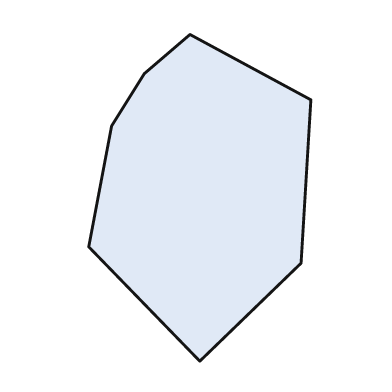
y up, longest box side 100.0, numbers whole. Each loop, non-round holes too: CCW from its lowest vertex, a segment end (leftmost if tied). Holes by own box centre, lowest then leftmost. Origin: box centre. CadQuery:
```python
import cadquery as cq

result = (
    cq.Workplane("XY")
    .moveTo(0.0, -50.0)
    .lineTo(31.0, -20.0)
    .lineTo(34.0, 30.0)
    .lineTo(-3.0, 50.0)
    .lineTo(-17.0, 38.0)
    .lineTo(-27.0, 22.0)
    .lineTo(-34.0, -15.0)
    .close()
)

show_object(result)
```